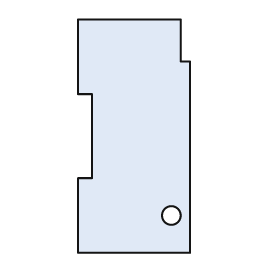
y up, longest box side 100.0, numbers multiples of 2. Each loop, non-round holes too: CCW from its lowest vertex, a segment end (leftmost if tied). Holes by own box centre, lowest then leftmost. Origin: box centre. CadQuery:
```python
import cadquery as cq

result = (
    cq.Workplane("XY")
    .moveTo(-24.0, -50.0)
    .lineTo(24.0, -50.0)
    .lineTo(24.0, 32.0)
    .lineTo(20.0, 32.0)
    .lineTo(20.0, 50.0)
    .lineTo(-24.0, 50.0)
    .lineTo(-24.0, 18.0)
    .lineTo(-18.0, 18.0)
    .lineTo(-18.0, -18.0)
    .lineTo(-24.0, -18.0)
    .close()
    .moveTo(16.0, -34.0)
    .circle(4.0)
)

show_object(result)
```